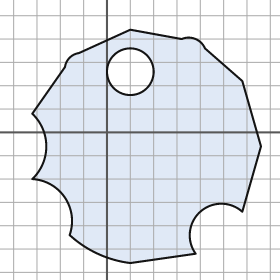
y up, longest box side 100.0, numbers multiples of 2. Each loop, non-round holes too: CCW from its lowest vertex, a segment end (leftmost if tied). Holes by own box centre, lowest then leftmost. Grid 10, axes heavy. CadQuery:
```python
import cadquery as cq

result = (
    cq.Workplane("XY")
    .moveTo(10.0, -56.0)
    .lineTo(38.0, -52.0)
    .threePointArc((40.0, -34.0), (58.0, -34.0))
    .lineTo(66.0, -6.0)
    .lineTo(58.0, 22.0)
    .lineTo(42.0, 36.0)
    .threePointArc((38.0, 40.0), (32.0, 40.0))
    .lineTo(10.0, 44.0)
    .lineTo(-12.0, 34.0)
    .threePointArc((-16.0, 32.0), (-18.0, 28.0))
    .lineTo(-32.0, 8.0)
    .threePointArc((-26.0, -6.0), (-32.0, -20.0))
    .threePointArc((-18.0, -28.0), (-16.0, -44.0))
    .threePointArc((-4.0, -52.0), (10.0, -56.0))
    .close()
    .moveTo(10.0, 26.0)
    .circle(10.0)
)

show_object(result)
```